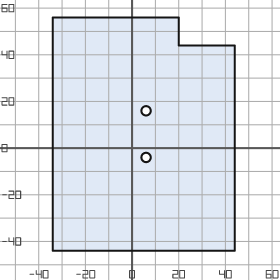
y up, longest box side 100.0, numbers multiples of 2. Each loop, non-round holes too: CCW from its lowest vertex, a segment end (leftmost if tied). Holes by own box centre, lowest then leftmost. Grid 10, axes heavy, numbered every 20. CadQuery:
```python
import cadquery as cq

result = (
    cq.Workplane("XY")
    .moveTo(-34.0, -44.0)
    .lineTo(44.0, -44.0)
    .lineTo(44.0, 44.0)
    .lineTo(20.0, 44.0)
    .lineTo(20.0, 56.0)
    .lineTo(-34.0, 56.0)
    .close()
    .moveTo(6.0, -4.0)
    .circle(2.0)
    .moveTo(6.0, 16.0)
    .circle(2.0)
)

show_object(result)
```